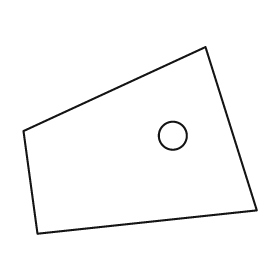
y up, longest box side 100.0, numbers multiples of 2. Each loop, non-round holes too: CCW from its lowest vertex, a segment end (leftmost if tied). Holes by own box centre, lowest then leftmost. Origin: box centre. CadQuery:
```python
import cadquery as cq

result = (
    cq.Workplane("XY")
    .moveTo(-44.0, -40.0)
    .lineTo(50.0, -30.0)
    .lineTo(28.0, 40.0)
    .lineTo(-50.0, 4.0)
    .close()
    .moveTo(14.0, 2.0)
    .circle(6.0)
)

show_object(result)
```